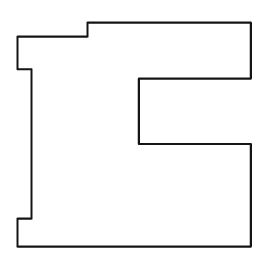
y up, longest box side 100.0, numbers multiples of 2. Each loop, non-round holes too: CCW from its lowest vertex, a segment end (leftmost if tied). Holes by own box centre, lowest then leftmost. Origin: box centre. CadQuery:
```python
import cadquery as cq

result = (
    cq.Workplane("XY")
    .moveTo(-50.0, -48.0)
    .lineTo(50.0, -48.0)
    .lineTo(50.0, -4.0)
    .lineTo(2.0, -4.0)
    .lineTo(2.0, 24.0)
    .lineTo(50.0, 24.0)
    .lineTo(50.0, 48.0)
    .lineTo(-20.0, 48.0)
    .lineTo(-20.0, 42.0)
    .lineTo(-50.0, 42.0)
    .lineTo(-50.0, 28.0)
    .lineTo(-44.0, 28.0)
    .lineTo(-44.0, -36.0)
    .lineTo(-50.0, -36.0)
    .close()
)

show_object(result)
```